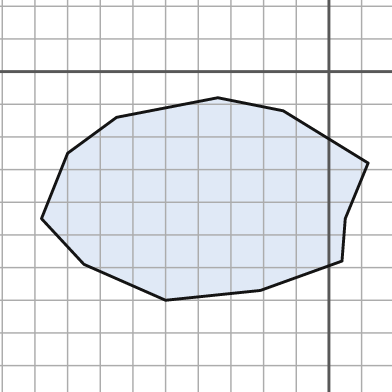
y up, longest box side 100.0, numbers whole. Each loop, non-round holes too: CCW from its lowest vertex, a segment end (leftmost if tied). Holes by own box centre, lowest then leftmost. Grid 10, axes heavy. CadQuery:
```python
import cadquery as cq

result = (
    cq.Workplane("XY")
    .moveTo(-50.0, -70.0)
    .lineTo(-21.0, -67.0)
    .lineTo(4.0, -58.0)
    .lineTo(5.0, -45.0)
    .lineTo(12.0, -28.0)
    .lineTo(-14.0, -12.0)
    .lineTo(-34.0, -8.0)
    .lineTo(-65.0, -14.0)
    .lineTo(-80.0, -25.0)
    .lineTo(-88.0, -45.0)
    .lineTo(-75.0, -59.0)
    .close()
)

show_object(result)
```